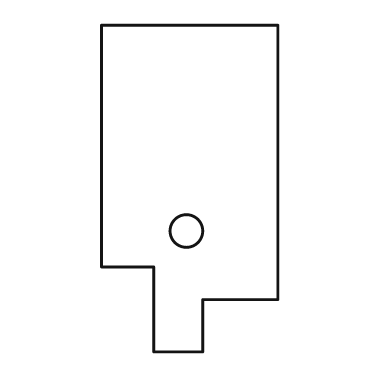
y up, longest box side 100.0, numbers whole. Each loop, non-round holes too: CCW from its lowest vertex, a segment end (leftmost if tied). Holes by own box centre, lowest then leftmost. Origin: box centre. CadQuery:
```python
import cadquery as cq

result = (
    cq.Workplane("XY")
    .moveTo(-11.0, -50.0)
    .lineTo(4.0, -50.0)
    .lineTo(4.0, -34.0)
    .lineTo(27.0, -34.0)
    .lineTo(27.0, 50.0)
    .lineTo(-27.0, 50.0)
    .lineTo(-27.0, -24.0)
    .lineTo(-11.0, -24.0)
    .close()
    .moveTo(-1.0, -13.0)
    .circle(5.0)
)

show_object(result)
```